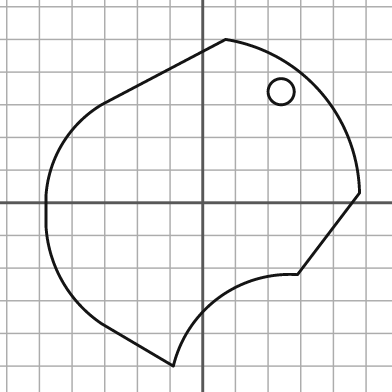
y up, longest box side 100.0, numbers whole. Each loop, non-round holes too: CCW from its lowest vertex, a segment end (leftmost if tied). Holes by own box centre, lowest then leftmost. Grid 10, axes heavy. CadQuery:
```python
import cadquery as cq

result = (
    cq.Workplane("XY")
    .moveTo(-9.0, -50.0)
    .threePointArc((5.0, -29.0), (29.0, -22.0))
    .lineTo(48.0, 3.0)
    .threePointArc((36.0, 34.0), (7.0, 50.0))
    .lineTo(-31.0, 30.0)
    .threePointArc((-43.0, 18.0), (-48.0, 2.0))
    .lineTo(-48.0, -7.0)
    .threePointArc((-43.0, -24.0), (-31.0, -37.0))
    .close()
    .moveTo(24.0, 34.0)
    .circle(4.0)
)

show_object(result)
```